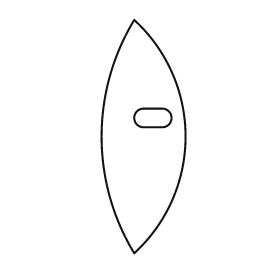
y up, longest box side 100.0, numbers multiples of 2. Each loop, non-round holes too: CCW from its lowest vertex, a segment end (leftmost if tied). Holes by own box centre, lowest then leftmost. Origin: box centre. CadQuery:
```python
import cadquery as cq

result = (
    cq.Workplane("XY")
    .moveTo(-4.0, -50.0)
    .threePointArc((18.0, 0.0), (-4.0, 50.0))
    .threePointArc((-18.0, 0.0), (-4.0, -50.0))
    .close()
    .moveTo(0.0, 4.0)
    .lineTo(8.0, 4.0)
    .threePointArc((12.0, 8.0), (8.0, 12.0))
    .lineTo(0.0, 12.0)
    .threePointArc((-4.0, 8.0), (0.0, 4.0))
    .close()
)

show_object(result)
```